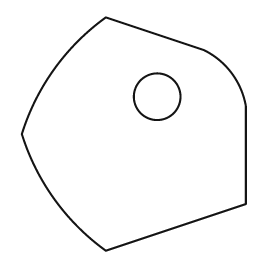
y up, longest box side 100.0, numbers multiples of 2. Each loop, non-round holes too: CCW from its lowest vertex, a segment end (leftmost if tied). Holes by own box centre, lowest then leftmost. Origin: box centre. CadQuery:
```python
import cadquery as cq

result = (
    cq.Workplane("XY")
    .moveTo(-12.0, -50.0)
    .lineTo(48.0, -30.0)
    .lineTo(48.0, 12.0)
    .threePointArc((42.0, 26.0), (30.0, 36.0))
    .lineTo(-12.0, 50.0)
    .threePointArc((-34.0, 28.0), (-48.0, 0.0))
    .threePointArc((-34.0, -28.0), (-12.0, -50.0))
    .close()
    .moveTo(10.0, 16.0)
    .circle(10.0)
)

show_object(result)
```